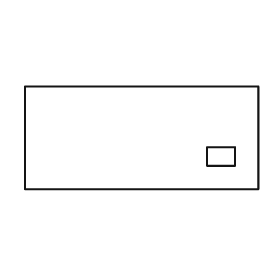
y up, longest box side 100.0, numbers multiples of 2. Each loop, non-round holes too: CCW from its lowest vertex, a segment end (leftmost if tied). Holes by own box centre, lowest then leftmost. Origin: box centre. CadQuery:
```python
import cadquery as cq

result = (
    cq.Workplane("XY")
    .moveTo(-50.0, -22.0)
    .lineTo(50.0, -22.0)
    .lineTo(50.0, 22.0)
    .lineTo(-50.0, 22.0)
    .close()
    .moveTo(28.0, -12.0)
    .lineTo(40.0, -12.0)
    .lineTo(40.0, -4.0)
    .lineTo(28.0, -4.0)
    .close()
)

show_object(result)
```